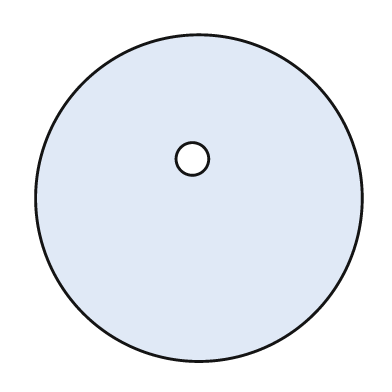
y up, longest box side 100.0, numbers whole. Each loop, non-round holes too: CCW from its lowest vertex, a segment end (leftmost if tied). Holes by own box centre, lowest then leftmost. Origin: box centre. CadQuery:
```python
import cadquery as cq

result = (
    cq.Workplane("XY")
    .moveTo(0.0, 0.0)
    .circle(50.0)
    .moveTo(-2.0, 12.0)
    .circle(5.0)
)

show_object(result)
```